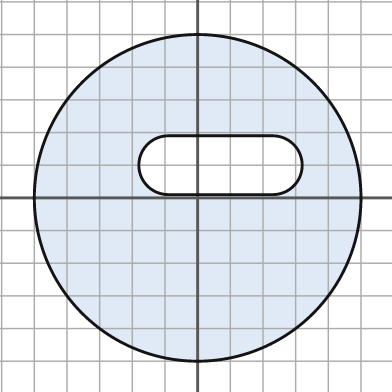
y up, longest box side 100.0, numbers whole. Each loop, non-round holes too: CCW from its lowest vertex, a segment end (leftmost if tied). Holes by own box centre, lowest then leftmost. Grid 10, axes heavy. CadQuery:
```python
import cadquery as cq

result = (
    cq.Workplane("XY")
    .moveTo(0.0, 0.0)
    .circle(50.0)
    .moveTo(-9.0, 1.0)
    .lineTo(23.0, 1.0)
    .threePointArc((32.0, 10.0), (23.0, 19.0))
    .lineTo(-9.0, 19.0)
    .threePointArc((-18.0, 10.0), (-9.0, 1.0))
    .close()
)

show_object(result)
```